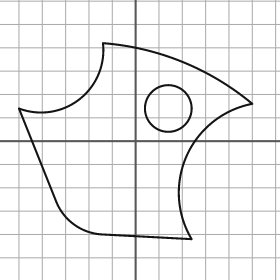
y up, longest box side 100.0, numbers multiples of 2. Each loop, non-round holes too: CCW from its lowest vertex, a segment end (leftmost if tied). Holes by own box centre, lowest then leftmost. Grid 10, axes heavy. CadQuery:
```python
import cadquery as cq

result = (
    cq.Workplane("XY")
    .moveTo(24.0, -42.0)
    .threePointArc((22.0, -6.0), (50.0, 16.0))
    .threePointArc((20.0, 34.0), (-14.0, 42.0))
    .threePointArc((-24.0, 18.0), (-50.0, 14.0))
    .lineTo(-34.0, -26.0)
    .threePointArc((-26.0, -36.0), (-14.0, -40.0))
    .close()
    .moveTo(14.0, 14.0)
    .circle(10.0)
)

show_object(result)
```